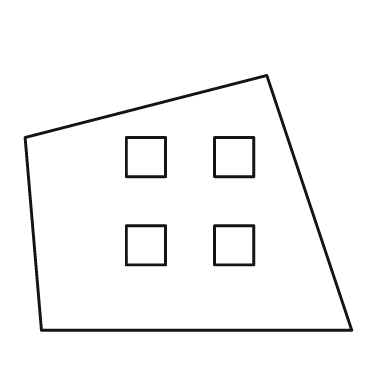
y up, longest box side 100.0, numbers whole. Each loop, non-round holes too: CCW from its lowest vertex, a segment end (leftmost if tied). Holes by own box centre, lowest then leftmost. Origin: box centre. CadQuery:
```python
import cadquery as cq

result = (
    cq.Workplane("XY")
    .moveTo(-45.0, -39.0)
    .lineTo(50.0, -39.0)
    .lineTo(24.0, 39.0)
    .lineTo(-50.0, 20.0)
    .close()
    .moveTo(-19.0, -19.0)
    .lineTo(-7.0, -19.0)
    .lineTo(-7.0, -7.0)
    .lineTo(-19.0, -7.0)
    .close()
    .moveTo(8.0, -19.0)
    .lineTo(20.0, -19.0)
    .lineTo(20.0, -7.0)
    .lineTo(8.0, -7.0)
    .close()
    .moveTo(-19.0, 8.0)
    .lineTo(-7.0, 8.0)
    .lineTo(-7.0, 20.0)
    .lineTo(-19.0, 20.0)
    .close()
    .moveTo(8.0, 8.0)
    .lineTo(20.0, 8.0)
    .lineTo(20.0, 20.0)
    .lineTo(8.0, 20.0)
    .close()
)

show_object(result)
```